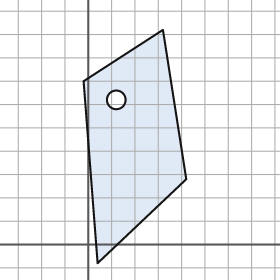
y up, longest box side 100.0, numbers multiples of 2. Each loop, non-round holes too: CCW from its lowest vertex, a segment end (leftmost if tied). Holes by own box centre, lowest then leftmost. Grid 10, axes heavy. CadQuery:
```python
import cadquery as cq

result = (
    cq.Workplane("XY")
    .moveTo(4.0, -8.0)
    .lineTo(42.0, 28.0)
    .lineTo(32.0, 92.0)
    .lineTo(-2.0, 70.0)
    .close()
    .moveTo(12.0, 62.0)
    .circle(4.0)
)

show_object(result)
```